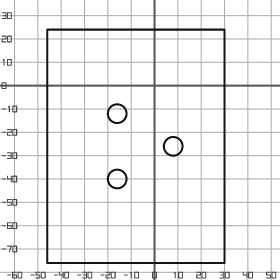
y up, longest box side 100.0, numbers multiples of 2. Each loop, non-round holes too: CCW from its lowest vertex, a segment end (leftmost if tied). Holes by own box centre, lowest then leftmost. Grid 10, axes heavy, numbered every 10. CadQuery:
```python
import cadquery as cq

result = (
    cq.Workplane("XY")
    .moveTo(-46.0, -76.0)
    .lineTo(30.0, -76.0)
    .lineTo(30.0, 24.0)
    .lineTo(-46.0, 24.0)
    .close()
    .moveTo(-16.0, -40.0)
    .circle(4.0)
    .moveTo(8.0, -26.0)
    .circle(4.0)
    .moveTo(-16.0, -12.0)
    .circle(4.0)
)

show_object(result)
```